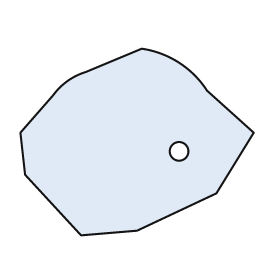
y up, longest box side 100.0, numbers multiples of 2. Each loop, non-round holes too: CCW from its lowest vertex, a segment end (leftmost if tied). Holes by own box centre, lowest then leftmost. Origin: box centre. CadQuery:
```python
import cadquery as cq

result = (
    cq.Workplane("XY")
    .moveTo(-24.0, -40.0)
    .lineTo(0.0, -38.0)
    .lineTo(34.0, -22.0)
    .lineTo(50.0, 4.0)
    .lineTo(30.0, 22.0)
    .threePointArc((18.0, 34.0), (2.0, 40.0))
    .lineTo(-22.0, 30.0)
    .threePointArc((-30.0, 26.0), (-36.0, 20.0))
    .lineTo(-50.0, 4.0)
    .lineTo(-48.0, -14.0)
    .close()
    .moveTo(18.0, -4.0)
    .circle(4.0)
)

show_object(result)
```